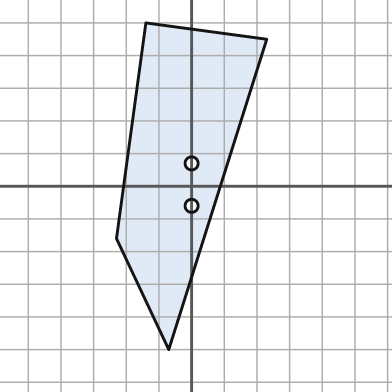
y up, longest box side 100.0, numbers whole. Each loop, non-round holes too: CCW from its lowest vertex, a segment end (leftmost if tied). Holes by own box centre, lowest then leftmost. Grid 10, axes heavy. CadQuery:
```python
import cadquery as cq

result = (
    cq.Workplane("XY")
    .moveTo(-7.0, -50.0)
    .lineTo(23.0, 45.0)
    .lineTo(-14.0, 50.0)
    .lineTo(-23.0, -16.0)
    .close()
    .moveTo(0.0, -6.0)
    .circle(2.0)
    .moveTo(0.0, 7.0)
    .circle(2.0)
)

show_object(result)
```